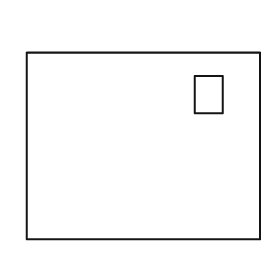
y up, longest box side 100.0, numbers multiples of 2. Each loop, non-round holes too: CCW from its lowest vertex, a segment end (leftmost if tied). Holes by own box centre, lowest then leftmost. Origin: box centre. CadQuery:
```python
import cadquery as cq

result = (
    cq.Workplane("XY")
    .moveTo(-50.0, -40.0)
    .lineTo(50.0, -40.0)
    .lineTo(50.0, 40.0)
    .lineTo(-50.0, 40.0)
    .close()
    .moveTo(22.0, 14.0)
    .lineTo(34.0, 14.0)
    .lineTo(34.0, 30.0)
    .lineTo(22.0, 30.0)
    .close()
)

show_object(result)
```